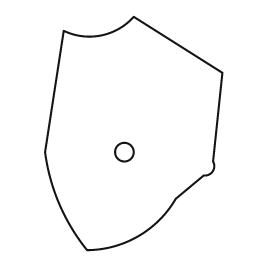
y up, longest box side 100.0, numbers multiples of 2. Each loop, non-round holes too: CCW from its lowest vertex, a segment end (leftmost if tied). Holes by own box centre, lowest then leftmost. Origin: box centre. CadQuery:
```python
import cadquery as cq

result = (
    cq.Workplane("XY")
    .moveTo(-20.0, -50.0)
    .threePointArc((2.0, -44.0), (18.0, -28.0))
    .lineTo(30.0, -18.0)
    .threePointArc((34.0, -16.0), (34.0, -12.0))
    .lineTo(38.0, 26.0)
    .lineTo(0.0, 50.0)
    .threePointArc((-14.0, 42.0), (-30.0, 44.0))
    .lineTo(-38.0, -8.0)
    .threePointArc((-32.0, -30.0), (-20.0, -50.0))
    .close()
    .moveTo(-4.0, -8.0)
    .circle(4.0)
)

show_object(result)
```